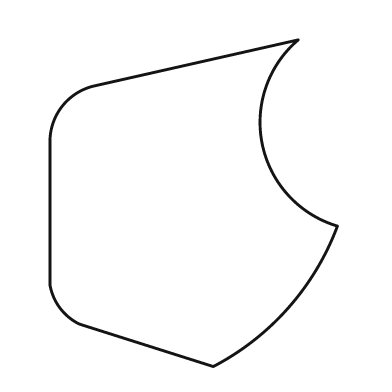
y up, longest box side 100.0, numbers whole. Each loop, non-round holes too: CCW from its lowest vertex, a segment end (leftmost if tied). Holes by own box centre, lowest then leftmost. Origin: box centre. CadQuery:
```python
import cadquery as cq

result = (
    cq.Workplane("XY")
    .moveTo(6.0, -50.0)
    .threePointArc((29.0, -32.0), (44.0, -7.0))
    .threePointArc((21.0, 18.0), (32.0, 50.0))
    .lineTo(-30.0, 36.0)
    .threePointArc((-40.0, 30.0), (-44.0, 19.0))
    .lineTo(-44.0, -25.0)
    .threePointArc((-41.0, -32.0), (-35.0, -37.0))
    .close()
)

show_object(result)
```